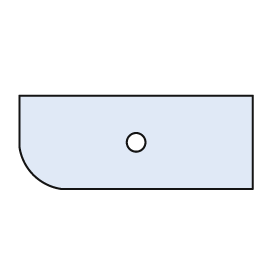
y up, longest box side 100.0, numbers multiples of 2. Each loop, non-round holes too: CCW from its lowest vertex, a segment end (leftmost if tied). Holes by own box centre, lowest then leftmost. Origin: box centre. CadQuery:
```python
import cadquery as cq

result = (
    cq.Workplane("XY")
    .moveTo(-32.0, -20.0)
    .lineTo(50.0, -20.0)
    .lineTo(50.0, 20.0)
    .lineTo(-50.0, 20.0)
    .lineTo(-50.0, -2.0)
    .threePointArc((-44.0, -14.0), (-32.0, -20.0))
    .close()
    .moveTo(0.0, 0.0)
    .circle(4.0)
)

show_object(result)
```